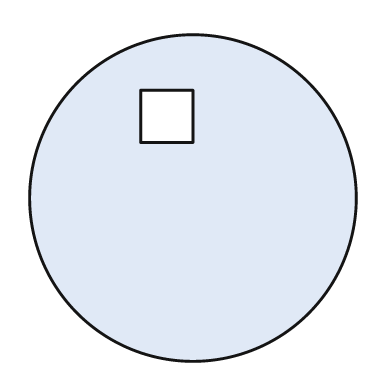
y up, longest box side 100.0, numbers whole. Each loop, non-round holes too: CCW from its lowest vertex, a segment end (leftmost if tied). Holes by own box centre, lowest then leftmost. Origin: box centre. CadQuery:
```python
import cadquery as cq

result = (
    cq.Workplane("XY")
    .moveTo(0.0, 0.0)
    .circle(50.0)
    .moveTo(-16.0, 17.0)
    .lineTo(0.0, 17.0)
    .lineTo(0.0, 33.0)
    .lineTo(-16.0, 33.0)
    .close()
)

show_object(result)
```